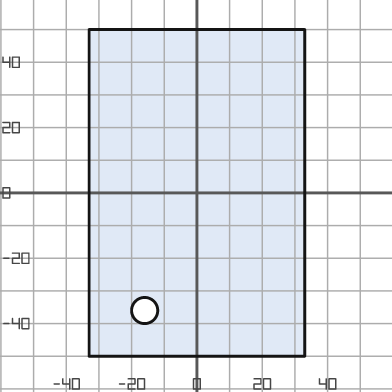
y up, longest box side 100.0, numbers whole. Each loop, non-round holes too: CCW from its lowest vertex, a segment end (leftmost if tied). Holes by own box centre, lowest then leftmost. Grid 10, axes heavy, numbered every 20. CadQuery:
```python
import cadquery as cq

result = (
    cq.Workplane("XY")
    .moveTo(-33.0, -50.0)
    .lineTo(33.0, -50.0)
    .lineTo(33.0, 50.0)
    .lineTo(-33.0, 50.0)
    .close()
    .moveTo(-16.0, -36.0)
    .circle(4.0)
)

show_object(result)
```